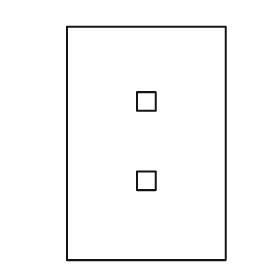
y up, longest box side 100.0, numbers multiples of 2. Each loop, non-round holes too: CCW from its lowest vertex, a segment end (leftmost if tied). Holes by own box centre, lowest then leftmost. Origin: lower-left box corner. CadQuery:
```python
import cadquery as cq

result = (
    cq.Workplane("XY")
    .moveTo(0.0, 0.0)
    .lineTo(68.0, 0.0)
    .lineTo(68.0, 100.0)
    .lineTo(0.0, 100.0)
    .close()
    .moveTo(30.0, 30.0)
    .lineTo(38.0, 30.0)
    .lineTo(38.0, 38.0)
    .lineTo(30.0, 38.0)
    .close()
    .moveTo(30.0, 64.0)
    .lineTo(38.0, 64.0)
    .lineTo(38.0, 72.0)
    .lineTo(30.0, 72.0)
    .close()
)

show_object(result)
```